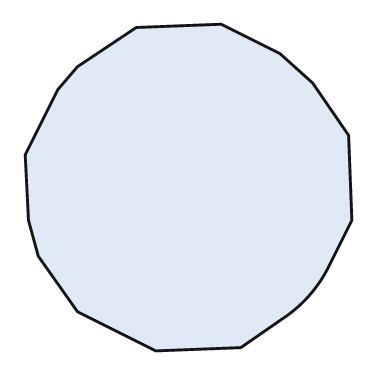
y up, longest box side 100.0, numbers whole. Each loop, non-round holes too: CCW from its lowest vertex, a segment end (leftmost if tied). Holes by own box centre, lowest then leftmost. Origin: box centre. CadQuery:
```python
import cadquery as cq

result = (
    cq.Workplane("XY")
    .moveTo(-10.0, -50.0)
    .lineTo(16.0, -49.0)
    .lineTo(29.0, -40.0)
    .threePointArc((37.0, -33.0), (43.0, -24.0))
    .lineTo(50.0, -10.0)
    .lineTo(49.0, 16.0)
    .lineTo(38.0, 32.0)
    .lineTo(28.0, 41.0)
    .lineTo(10.0, 50.0)
    .lineTo(-16.0, 49.0)
    .lineTo(-34.0, 37.0)
    .lineTo(-40.0, 30.0)
    .lineTo(-50.0, 10.0)
    .lineTo(-49.0, -10.0)
    .lineTo(-46.0, -21.0)
    .lineTo(-34.0, -38.0)
    .close()
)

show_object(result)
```